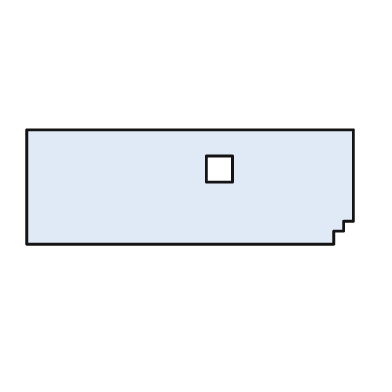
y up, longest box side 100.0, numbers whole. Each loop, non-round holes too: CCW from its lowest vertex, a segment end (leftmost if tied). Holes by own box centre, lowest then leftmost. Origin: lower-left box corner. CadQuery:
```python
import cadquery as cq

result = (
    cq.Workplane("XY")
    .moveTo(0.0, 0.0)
    .lineTo(94.0, 0.0)
    .lineTo(94.0, 4.0)
    .lineTo(97.0, 4.0)
    .lineTo(97.0, 7.0)
    .lineTo(100.0, 7.0)
    .lineTo(100.0, 35.0)
    .lineTo(0.0, 35.0)
    .close()
    .moveTo(55.0, 19.0)
    .lineTo(63.0, 19.0)
    .lineTo(63.0, 27.0)
    .lineTo(55.0, 27.0)
    .close()
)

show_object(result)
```